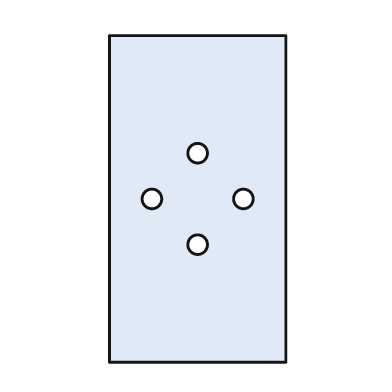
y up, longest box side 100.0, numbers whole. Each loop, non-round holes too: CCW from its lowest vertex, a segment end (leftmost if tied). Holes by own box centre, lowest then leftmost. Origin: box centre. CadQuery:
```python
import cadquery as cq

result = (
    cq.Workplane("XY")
    .moveTo(-27.0, -50.0)
    .lineTo(27.0, -50.0)
    .lineTo(27.0, 50.0)
    .lineTo(-27.0, 50.0)
    .close()
    .moveTo(0.0, -14.0)
    .circle(3.0)
    .moveTo(-14.0, 0.0)
    .circle(3.0)
    .moveTo(14.0, 0.0)
    .circle(3.0)
    .moveTo(0.0, 14.0)
    .circle(3.0)
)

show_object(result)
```